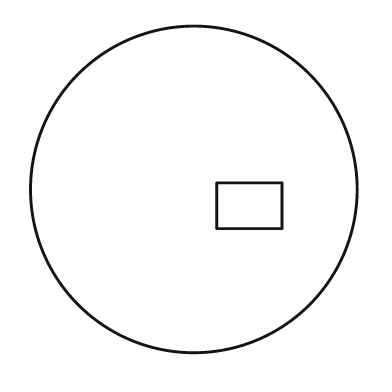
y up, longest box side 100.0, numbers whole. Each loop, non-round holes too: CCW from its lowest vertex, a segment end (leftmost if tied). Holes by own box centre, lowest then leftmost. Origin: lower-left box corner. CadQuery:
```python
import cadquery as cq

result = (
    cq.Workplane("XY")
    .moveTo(50.0, 50.0)
    .circle(50.0)
    .moveTo(57.0, 38.0)
    .lineTo(77.0, 38.0)
    .lineTo(77.0, 52.0)
    .lineTo(57.0, 52.0)
    .close()
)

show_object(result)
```